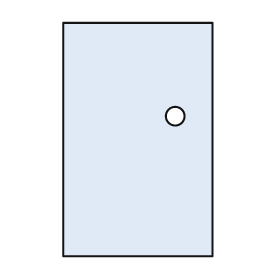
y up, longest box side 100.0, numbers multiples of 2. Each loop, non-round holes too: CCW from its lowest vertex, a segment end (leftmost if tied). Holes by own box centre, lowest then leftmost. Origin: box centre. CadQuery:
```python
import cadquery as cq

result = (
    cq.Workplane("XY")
    .moveTo(-32.0, -50.0)
    .lineTo(32.0, -50.0)
    .lineTo(32.0, 50.0)
    .lineTo(-32.0, 50.0)
    .close()
    .moveTo(16.0, 10.0)
    .circle(4.0)
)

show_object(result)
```